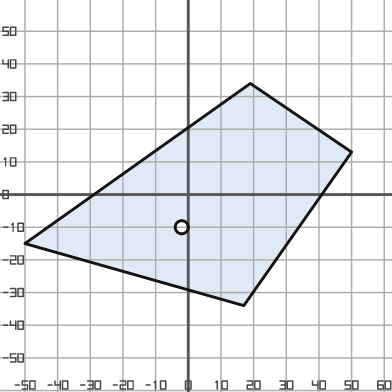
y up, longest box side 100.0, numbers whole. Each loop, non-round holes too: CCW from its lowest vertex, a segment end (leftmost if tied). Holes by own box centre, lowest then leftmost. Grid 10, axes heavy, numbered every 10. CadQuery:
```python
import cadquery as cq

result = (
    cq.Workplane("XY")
    .moveTo(17.0, -34.0)
    .lineTo(50.0, 13.0)
    .lineTo(19.0, 34.0)
    .lineTo(-50.0, -15.0)
    .close()
    .moveTo(-2.0, -10.0)
    .circle(2.0)
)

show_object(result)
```